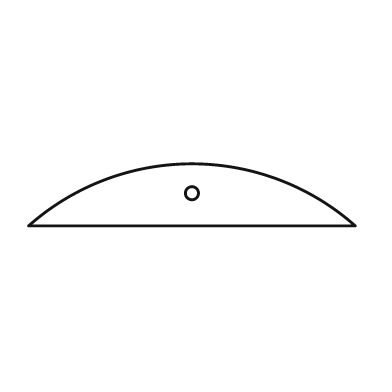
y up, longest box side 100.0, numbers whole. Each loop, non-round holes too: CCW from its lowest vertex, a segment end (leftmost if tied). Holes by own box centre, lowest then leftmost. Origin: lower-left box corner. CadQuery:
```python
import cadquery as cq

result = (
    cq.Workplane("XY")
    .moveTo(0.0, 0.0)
    .lineTo(100.0, 0.0)
    .threePointArc((50.0, 19.0), (0.0, 0.0))
    .close()
    .moveTo(50.0, 10.0)
    .circle(2.0)
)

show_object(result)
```